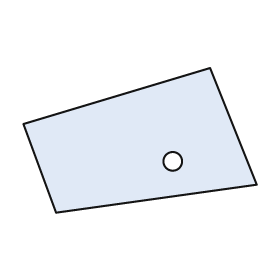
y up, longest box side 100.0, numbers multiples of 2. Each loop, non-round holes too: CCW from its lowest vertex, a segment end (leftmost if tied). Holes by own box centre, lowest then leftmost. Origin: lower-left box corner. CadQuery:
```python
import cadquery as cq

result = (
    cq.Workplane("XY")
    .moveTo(14.0, 0.0)
    .lineTo(100.0, 12.0)
    .lineTo(80.0, 62.0)
    .lineTo(0.0, 38.0)
    .close()
    .moveTo(64.0, 22.0)
    .circle(4.0)
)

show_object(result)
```